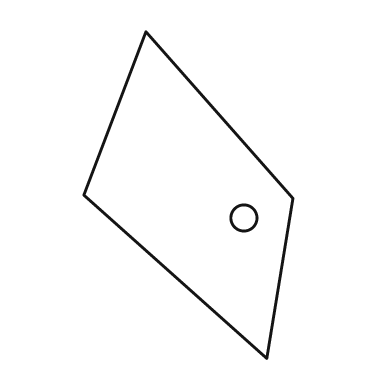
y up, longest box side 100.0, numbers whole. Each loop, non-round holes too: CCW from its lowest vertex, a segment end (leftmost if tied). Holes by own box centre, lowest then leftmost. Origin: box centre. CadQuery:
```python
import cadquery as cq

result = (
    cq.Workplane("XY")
    .moveTo(24.0, -50.0)
    .lineTo(32.0, -1.0)
    .lineTo(-13.0, 50.0)
    .lineTo(-32.0, 0.0)
    .close()
    .moveTo(17.0, -7.0)
    .circle(4.0)
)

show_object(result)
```